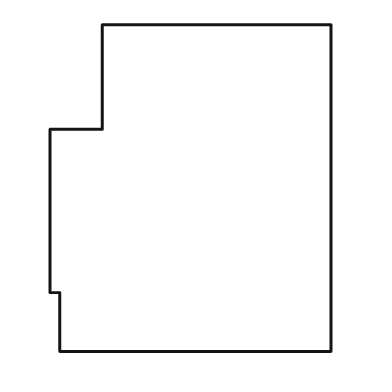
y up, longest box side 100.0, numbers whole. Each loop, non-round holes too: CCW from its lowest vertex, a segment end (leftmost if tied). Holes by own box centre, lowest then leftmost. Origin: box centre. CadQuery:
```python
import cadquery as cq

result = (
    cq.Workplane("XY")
    .moveTo(-40.0, -50.0)
    .lineTo(43.0, -50.0)
    .lineTo(43.0, 50.0)
    .lineTo(-27.0, 50.0)
    .lineTo(-27.0, 18.0)
    .lineTo(-43.0, 18.0)
    .lineTo(-43.0, -32.0)
    .lineTo(-40.0, -32.0)
    .close()
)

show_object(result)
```